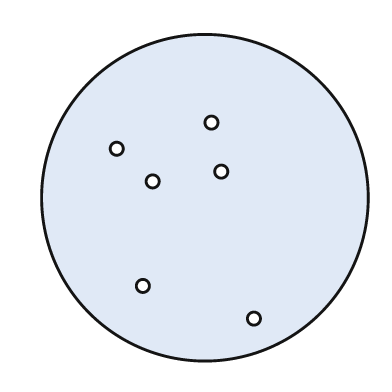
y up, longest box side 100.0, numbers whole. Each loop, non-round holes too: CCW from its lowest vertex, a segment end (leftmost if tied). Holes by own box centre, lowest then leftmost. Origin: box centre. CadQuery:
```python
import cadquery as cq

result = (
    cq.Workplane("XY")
    .moveTo(0.0, 0.0)
    .circle(50.0)
    .moveTo(15.0, -37.0)
    .circle(2.0)
    .moveTo(-19.0, -27.0)
    .circle(2.0)
    .moveTo(-16.0, 5.0)
    .circle(2.0)
    .moveTo(5.0, 8.0)
    .circle(2.0)
    .moveTo(-27.0, 15.0)
    .circle(2.0)
    .moveTo(2.0, 23.0)
    .circle(2.0)
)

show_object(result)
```